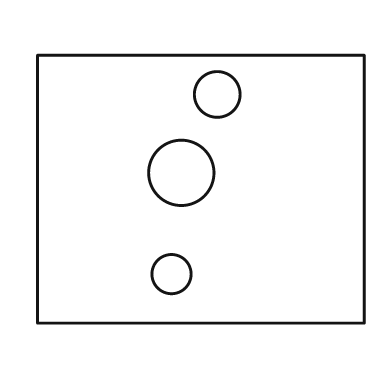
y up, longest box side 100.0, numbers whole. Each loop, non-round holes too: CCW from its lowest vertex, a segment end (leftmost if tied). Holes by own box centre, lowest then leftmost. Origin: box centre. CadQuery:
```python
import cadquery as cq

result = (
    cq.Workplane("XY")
    .moveTo(-50.0, -41.0)
    .lineTo(50.0, -41.0)
    .lineTo(50.0, 41.0)
    .lineTo(-50.0, 41.0)
    .close()
    .moveTo(-9.0, -26.0)
    .circle(6.0)
    .moveTo(-6.0, 5.0)
    .circle(10.0)
    .moveTo(5.0, 29.0)
    .circle(7.0)
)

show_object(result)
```